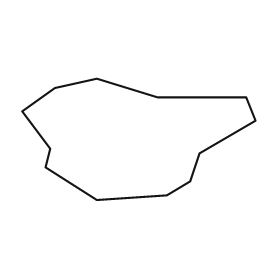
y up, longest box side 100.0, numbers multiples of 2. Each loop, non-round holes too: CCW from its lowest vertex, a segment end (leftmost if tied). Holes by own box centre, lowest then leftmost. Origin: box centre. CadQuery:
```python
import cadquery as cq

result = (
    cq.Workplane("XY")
    .moveTo(-18.0, -26.0)
    .lineTo(12.0, -24.0)
    .lineTo(22.0, -18.0)
    .lineTo(26.0, -6.0)
    .lineTo(50.0, 8.0)
    .lineTo(46.0, 18.0)
    .lineTo(8.0, 18.0)
    .lineTo(-18.0, 26.0)
    .lineTo(-36.0, 22.0)
    .lineTo(-50.0, 12.0)
    .lineTo(-38.0, -4.0)
    .lineTo(-40.0, -12.0)
    .close()
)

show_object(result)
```